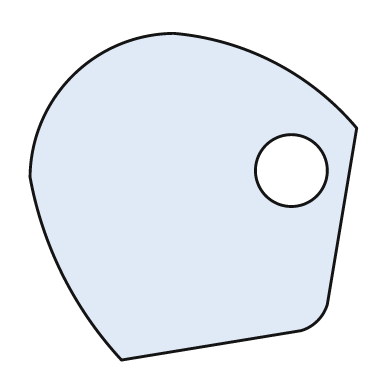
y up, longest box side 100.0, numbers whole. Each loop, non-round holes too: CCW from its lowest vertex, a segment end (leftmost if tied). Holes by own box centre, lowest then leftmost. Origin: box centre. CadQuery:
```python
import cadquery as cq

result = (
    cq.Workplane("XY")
    .moveTo(-22.0, -50.0)
    .lineTo(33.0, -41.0)
    .threePointArc((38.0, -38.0), (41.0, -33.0))
    .lineTo(50.0, 21.0)
    .threePointArc((25.0, 41.0), (-6.0, 50.0))
    .threePointArc((-37.0, 37.0), (-50.0, 6.0))
    .threePointArc((-40.0, -24.0), (-22.0, -50.0))
    .close()
    .moveTo(30.0, 8.0)
    .circle(11.0)
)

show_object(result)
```